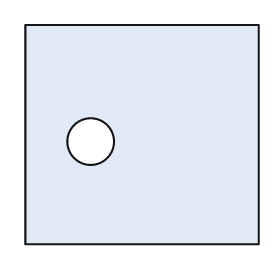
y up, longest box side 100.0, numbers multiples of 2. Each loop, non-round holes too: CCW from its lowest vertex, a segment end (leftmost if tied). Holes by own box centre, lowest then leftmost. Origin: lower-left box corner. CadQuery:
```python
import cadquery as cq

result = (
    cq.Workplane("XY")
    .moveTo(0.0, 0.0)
    .lineTo(100.0, 0.0)
    .lineTo(100.0, 94.0)
    .lineTo(0.0, 94.0)
    .close()
    .moveTo(28.0, 44.0)
    .circle(10.0)
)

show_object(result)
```